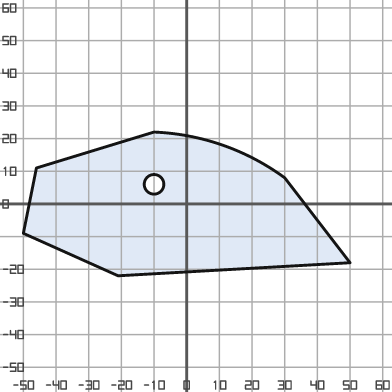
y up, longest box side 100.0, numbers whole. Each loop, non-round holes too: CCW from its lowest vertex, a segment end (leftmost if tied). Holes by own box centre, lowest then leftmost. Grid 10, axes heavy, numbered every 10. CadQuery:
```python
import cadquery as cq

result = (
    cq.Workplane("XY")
    .moveTo(-21.0, -22.0)
    .lineTo(50.0, -18.0)
    .lineTo(30.0, 8.0)
    .threePointArc((11.0, 18.0), (-10.0, 22.0))
    .lineTo(-46.0, 11.0)
    .lineTo(-50.0, -9.0)
    .close()
    .moveTo(-10.0, 6.0)
    .circle(3.0)
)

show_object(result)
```